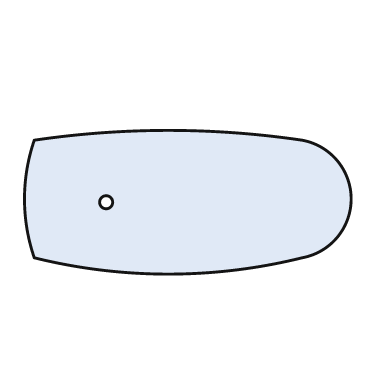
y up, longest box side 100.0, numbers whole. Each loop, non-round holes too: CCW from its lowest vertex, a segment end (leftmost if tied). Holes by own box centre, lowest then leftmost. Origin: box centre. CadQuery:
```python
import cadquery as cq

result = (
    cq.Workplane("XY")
    .moveTo(-47.0, -17.0)
    .threePointArc((-6.0, -22.0), (35.0, -17.0))
    .threePointArc((50.0, 1.0), (35.0, 19.0))
    .threePointArc((-6.0, 22.0), (-47.0, 19.0))
    .threePointArc((-50.0, 1.0), (-47.0, -17.0))
    .close()
    .moveTo(-25.0, 0.0)
    .circle(2.0)
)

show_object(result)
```